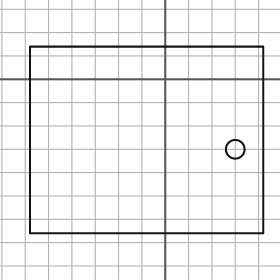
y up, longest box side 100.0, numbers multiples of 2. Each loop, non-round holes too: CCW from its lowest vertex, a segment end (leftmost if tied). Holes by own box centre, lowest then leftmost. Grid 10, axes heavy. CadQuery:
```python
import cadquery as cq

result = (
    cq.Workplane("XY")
    .moveTo(-58.0, -66.0)
    .lineTo(42.0, -66.0)
    .lineTo(42.0, 14.0)
    .lineTo(-58.0, 14.0)
    .close()
    .moveTo(30.0, -30.0)
    .circle(4.0)
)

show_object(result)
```